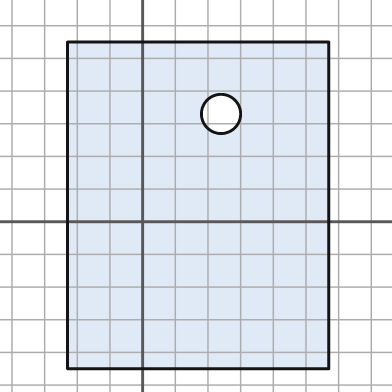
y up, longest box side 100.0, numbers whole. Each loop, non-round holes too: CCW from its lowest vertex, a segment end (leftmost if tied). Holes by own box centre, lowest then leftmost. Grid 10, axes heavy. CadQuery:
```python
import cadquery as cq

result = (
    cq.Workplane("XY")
    .moveTo(-23.0, -45.0)
    .lineTo(57.0, -45.0)
    .lineTo(57.0, 55.0)
    .lineTo(-23.0, 55.0)
    .close()
    .moveTo(24.0, 33.0)
    .circle(6.0)
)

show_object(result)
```